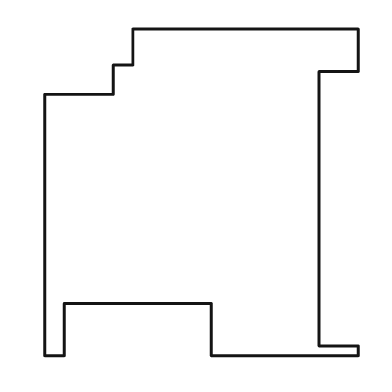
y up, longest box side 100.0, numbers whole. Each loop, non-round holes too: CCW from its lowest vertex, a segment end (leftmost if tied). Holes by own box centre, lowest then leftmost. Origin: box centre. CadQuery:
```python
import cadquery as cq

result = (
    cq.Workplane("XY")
    .moveTo(-48.0, -50.0)
    .lineTo(-42.0, -50.0)
    .lineTo(-42.0, -34.0)
    .lineTo(3.0, -34.0)
    .lineTo(3.0, -50.0)
    .lineTo(48.0, -50.0)
    .lineTo(48.0, -47.0)
    .lineTo(36.0, -47.0)
    .lineTo(36.0, 37.0)
    .lineTo(48.0, 37.0)
    .lineTo(48.0, 50.0)
    .lineTo(-21.0, 50.0)
    .lineTo(-21.0, 39.0)
    .lineTo(-27.0, 39.0)
    .lineTo(-27.0, 30.0)
    .lineTo(-48.0, 30.0)
    .close()
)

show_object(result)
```